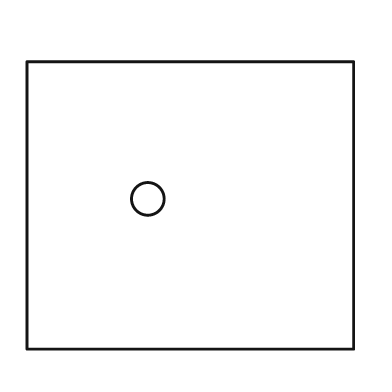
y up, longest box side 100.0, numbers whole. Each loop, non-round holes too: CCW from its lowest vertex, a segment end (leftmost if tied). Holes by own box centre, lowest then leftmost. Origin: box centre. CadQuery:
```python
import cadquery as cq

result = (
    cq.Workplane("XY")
    .moveTo(-50.0, -44.0)
    .lineTo(50.0, -44.0)
    .lineTo(50.0, 44.0)
    .lineTo(-50.0, 44.0)
    .close()
    .moveTo(-13.0, 2.0)
    .circle(5.0)
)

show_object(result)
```